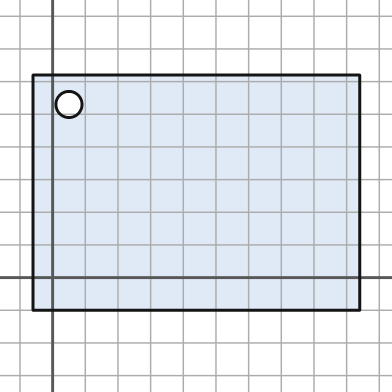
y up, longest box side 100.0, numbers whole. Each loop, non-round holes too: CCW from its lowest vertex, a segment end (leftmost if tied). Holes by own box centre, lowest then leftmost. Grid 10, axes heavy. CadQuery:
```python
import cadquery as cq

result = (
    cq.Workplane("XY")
    .moveTo(-6.0, -10.0)
    .lineTo(94.0, -10.0)
    .lineTo(94.0, 62.0)
    .lineTo(-6.0, 62.0)
    .close()
    .moveTo(5.0, 53.0)
    .circle(4.0)
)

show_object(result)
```